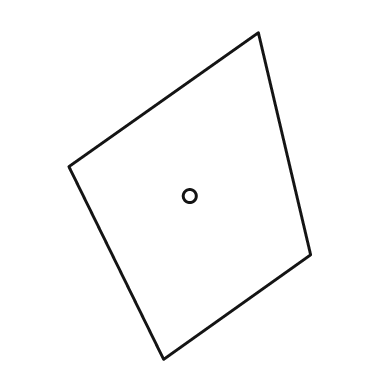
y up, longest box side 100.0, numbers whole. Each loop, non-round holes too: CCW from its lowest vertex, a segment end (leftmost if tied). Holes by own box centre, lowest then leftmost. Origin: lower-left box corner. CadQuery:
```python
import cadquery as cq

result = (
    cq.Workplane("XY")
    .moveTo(29.0, 0.0)
    .lineTo(74.0, 32.0)
    .lineTo(58.0, 100.0)
    .lineTo(0.0, 59.0)
    .close()
    .moveTo(37.0, 50.0)
    .circle(2.0)
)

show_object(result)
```